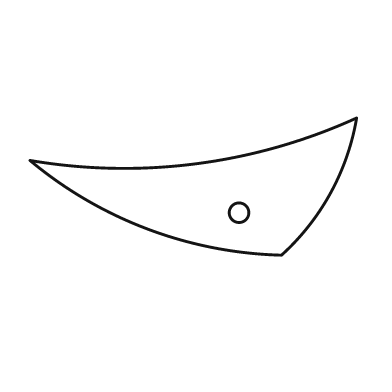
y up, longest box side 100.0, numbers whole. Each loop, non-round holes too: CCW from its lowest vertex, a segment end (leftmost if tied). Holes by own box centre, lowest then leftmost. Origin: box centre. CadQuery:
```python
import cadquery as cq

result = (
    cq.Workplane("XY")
    .moveTo(27.0, -21.0)
    .threePointArc((42.0, -2.0), (50.0, 21.0))
    .threePointArc((1.0, 7.0), (-50.0, 8.0))
    .threePointArc((-14.0, -13.0), (27.0, -21.0))
    .close()
    .moveTo(14.0, -8.0)
    .circle(3.0)
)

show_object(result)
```